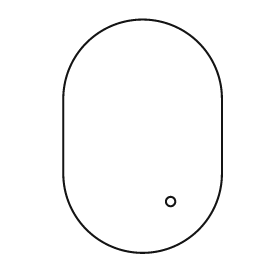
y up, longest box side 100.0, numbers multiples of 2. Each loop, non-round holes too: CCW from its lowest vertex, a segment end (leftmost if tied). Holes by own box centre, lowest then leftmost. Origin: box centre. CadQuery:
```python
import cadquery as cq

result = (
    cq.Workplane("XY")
    .moveTo(-34.0, -16.0)
    .threePointArc((0.0, -50.0), (34.0, -16.0))
    .lineTo(34.0, 16.0)
    .threePointArc((0.0, 50.0), (-34.0, 16.0))
    .close()
    .moveTo(12.0, -28.0)
    .circle(2.0)
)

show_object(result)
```